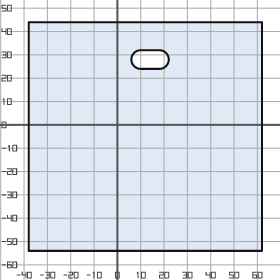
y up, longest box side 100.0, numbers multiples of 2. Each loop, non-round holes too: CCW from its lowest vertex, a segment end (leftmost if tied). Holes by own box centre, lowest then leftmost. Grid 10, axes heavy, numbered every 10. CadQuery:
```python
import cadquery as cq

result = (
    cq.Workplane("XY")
    .moveTo(-38.0, -54.0)
    .lineTo(62.0, -54.0)
    .lineTo(62.0, 44.0)
    .lineTo(-38.0, 44.0)
    .close()
    .moveTo(10.0, 24.0)
    .lineTo(18.0, 24.0)
    .threePointArc((22.0, 28.0), (18.0, 32.0))
    .lineTo(10.0, 32.0)
    .threePointArc((6.0, 28.0), (10.0, 24.0))
    .close()
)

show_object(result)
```